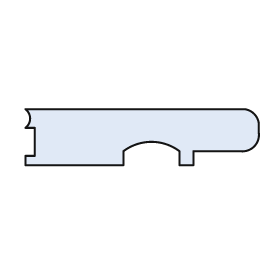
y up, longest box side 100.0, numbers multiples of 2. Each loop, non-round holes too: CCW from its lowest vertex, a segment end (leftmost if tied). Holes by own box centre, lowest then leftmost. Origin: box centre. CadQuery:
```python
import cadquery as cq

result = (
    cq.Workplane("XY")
    .moveTo(-50.0, -12.0)
    .lineTo(-8.0, -12.0)
    .lineTo(-8.0, -6.0)
    .threePointArc((4.0, -2.0), (16.0, -6.0))
    .lineTo(16.0, -12.0)
    .lineTo(22.0, -12.0)
    .lineTo(22.0, -6.0)
    .lineTo(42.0, -6.0)
    .threePointArc((48.0, -4.0), (50.0, 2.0))
    .lineTo(50.0, 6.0)
    .threePointArc((48.0, 10.0), (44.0, 12.0))
    .lineTo(-50.0, 12.0)
    .threePointArc((-48.0, 8.0), (-50.0, 4.0))
    .lineTo(-46.0, 4.0)
    .lineTo(-46.0, -8.0)
    .lineTo(-50.0, -8.0)
    .close()
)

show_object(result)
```